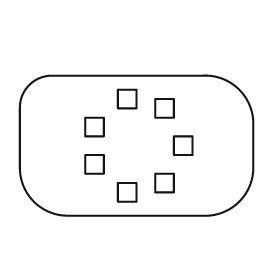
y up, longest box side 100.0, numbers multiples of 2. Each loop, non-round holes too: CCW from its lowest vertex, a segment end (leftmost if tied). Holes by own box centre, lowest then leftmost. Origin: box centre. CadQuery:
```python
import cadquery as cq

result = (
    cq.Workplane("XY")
    .moveTo(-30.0, -30.0)
    .lineTo(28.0, -30.0)
    .threePointArc((44.0, -24.0), (50.0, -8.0))
    .lineTo(50.0, 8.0)
    .threePointArc((44.0, 24.0), (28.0, 30.0))
    .lineTo(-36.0, 30.0)
    .threePointArc((-46.0, 26.0), (-50.0, 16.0))
    .lineTo(-50.0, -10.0)
    .threePointArc((-44.0, -24.0), (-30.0, -30.0))
    .close()
    .moveTo(-8.0, -24.0)
    .lineTo(0.0, -24.0)
    .lineTo(0.0, -16.0)
    .lineTo(-8.0, -16.0)
    .close()
    .moveTo(8.0, -20.0)
    .lineTo(16.0, -20.0)
    .lineTo(16.0, -12.0)
    .lineTo(8.0, -12.0)
    .close()
    .moveTo(-22.0, -12.0)
    .lineTo(-14.0, -12.0)
    .lineTo(-14.0, -4.0)
    .lineTo(-22.0, -4.0)
    .close()
    .moveTo(16.0, -4.0)
    .lineTo(24.0, -4.0)
    .lineTo(24.0, 4.0)
    .lineTo(16.0, 4.0)
    .close()
    .moveTo(-22.0, 4.0)
    .lineTo(-14.0, 4.0)
    .lineTo(-14.0, 12.0)
    .lineTo(-22.0, 12.0)
    .close()
    .moveTo(8.0, 12.0)
    .lineTo(16.0, 12.0)
    .lineTo(16.0, 20.0)
    .lineTo(8.0, 20.0)
    .close()
    .moveTo(-8.0, 16.0)
    .lineTo(0.0, 16.0)
    .lineTo(0.0, 24.0)
    .lineTo(-8.0, 24.0)
    .close()
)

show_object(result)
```